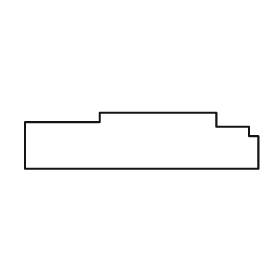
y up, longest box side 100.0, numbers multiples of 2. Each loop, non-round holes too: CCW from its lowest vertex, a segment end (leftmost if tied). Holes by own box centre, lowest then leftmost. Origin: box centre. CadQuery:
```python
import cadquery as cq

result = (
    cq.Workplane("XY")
    .moveTo(-50.0, -12.0)
    .lineTo(50.0, -12.0)
    .lineTo(50.0, 2.0)
    .lineTo(46.0, 2.0)
    .lineTo(46.0, 6.0)
    .lineTo(32.0, 6.0)
    .lineTo(32.0, 12.0)
    .lineTo(-18.0, 12.0)
    .lineTo(-18.0, 8.0)
    .lineTo(-50.0, 8.0)
    .close()
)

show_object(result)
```